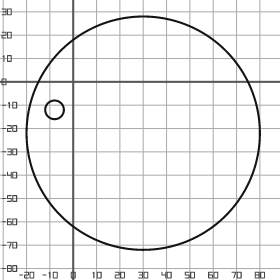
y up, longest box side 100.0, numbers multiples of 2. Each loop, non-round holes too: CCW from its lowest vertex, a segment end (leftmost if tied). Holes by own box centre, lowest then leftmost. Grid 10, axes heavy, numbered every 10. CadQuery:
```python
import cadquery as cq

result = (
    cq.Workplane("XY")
    .moveTo(30.0, -22.0)
    .circle(50.0)
    .moveTo(-8.0, -12.0)
    .circle(4.0)
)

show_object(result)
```